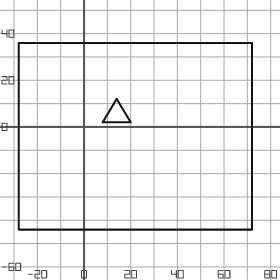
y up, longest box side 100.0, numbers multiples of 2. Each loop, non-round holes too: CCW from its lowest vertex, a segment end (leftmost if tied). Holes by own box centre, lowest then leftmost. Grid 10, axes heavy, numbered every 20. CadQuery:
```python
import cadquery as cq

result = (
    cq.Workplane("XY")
    .moveTo(-28.0, -44.0)
    .lineTo(72.0, -44.0)
    .lineTo(72.0, 36.0)
    .lineTo(-28.0, 36.0)
    .close()
    .moveTo(8.0, 2.0)
    .lineTo(20.0, 2.0)
    .lineTo(14.0, 12.0)
    .close()
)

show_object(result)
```